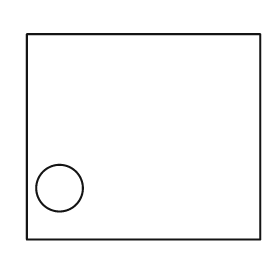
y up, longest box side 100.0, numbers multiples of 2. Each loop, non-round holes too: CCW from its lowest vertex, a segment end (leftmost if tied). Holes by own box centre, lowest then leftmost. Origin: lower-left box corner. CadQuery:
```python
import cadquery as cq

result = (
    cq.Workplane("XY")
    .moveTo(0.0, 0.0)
    .lineTo(100.0, 0.0)
    .lineTo(100.0, 88.0)
    .lineTo(0.0, 88.0)
    .close()
    .moveTo(14.0, 22.0)
    .circle(10.0)
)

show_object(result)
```